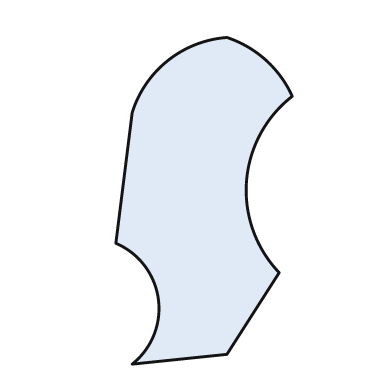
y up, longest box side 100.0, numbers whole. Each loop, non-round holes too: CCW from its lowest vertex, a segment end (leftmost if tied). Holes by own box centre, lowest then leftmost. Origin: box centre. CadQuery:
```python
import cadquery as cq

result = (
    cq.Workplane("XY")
    .moveTo(-22.0, -50.0)
    .lineTo(7.0, -47.0)
    .lineTo(23.0, -22.0)
    .threePointArc((13.0, 6.0), (27.0, 32.0))
    .threePointArc((19.0, 43.0), (7.0, 50.0))
    .threePointArc((-11.0, 43.0), (-22.0, 27.0))
    .lineTo(-27.0, -13.0)
    .threePointArc((-14.0, -30.0), (-22.0, -50.0))
    .close()
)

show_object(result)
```